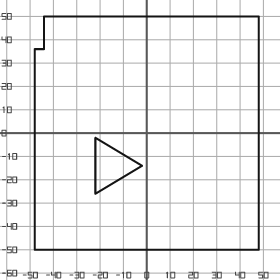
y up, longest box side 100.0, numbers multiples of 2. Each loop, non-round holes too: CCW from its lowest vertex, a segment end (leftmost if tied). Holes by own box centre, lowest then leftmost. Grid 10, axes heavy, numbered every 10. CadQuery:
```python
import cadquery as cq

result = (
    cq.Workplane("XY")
    .moveTo(-48.0, -50.0)
    .lineTo(48.0, -50.0)
    .lineTo(48.0, 50.0)
    .lineTo(-44.0, 50.0)
    .lineTo(-44.0, 36.0)
    .lineTo(-48.0, 36.0)
    .close()
    .moveTo(-22.0, -26.0)
    .lineTo(-2.0, -14.0)
    .lineTo(-22.0, -2.0)
    .close()
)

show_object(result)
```